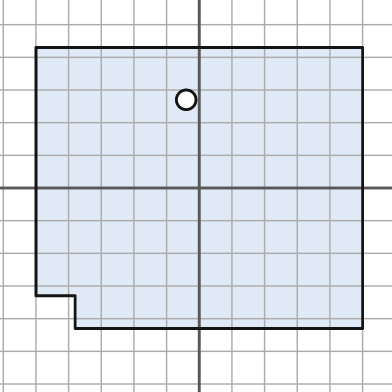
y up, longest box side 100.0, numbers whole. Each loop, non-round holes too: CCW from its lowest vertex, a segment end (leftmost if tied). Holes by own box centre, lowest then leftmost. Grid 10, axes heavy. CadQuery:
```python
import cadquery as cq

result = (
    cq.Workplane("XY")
    .moveTo(-38.0, -43.0)
    .lineTo(50.0, -43.0)
    .lineTo(50.0, 43.0)
    .lineTo(-50.0, 43.0)
    .lineTo(-50.0, -33.0)
    .lineTo(-38.0, -33.0)
    .close()
    .moveTo(-4.0, 27.0)
    .circle(3.0)
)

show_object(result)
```